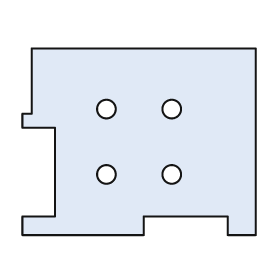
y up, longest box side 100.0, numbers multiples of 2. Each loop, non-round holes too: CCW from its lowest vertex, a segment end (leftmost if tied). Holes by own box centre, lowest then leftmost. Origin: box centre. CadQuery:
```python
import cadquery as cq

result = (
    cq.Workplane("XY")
    .moveTo(-50.0, -40.0)
    .lineTo(2.0, -40.0)
    .lineTo(2.0, -32.0)
    .lineTo(38.0, -32.0)
    .lineTo(38.0, -40.0)
    .lineTo(50.0, -40.0)
    .lineTo(50.0, 40.0)
    .lineTo(-46.0, 40.0)
    .lineTo(-46.0, 12.0)
    .lineTo(-50.0, 12.0)
    .lineTo(-50.0, 6.0)
    .lineTo(-36.0, 6.0)
    .lineTo(-36.0, -32.0)
    .lineTo(-50.0, -32.0)
    .close()
    .moveTo(-14.0, -14.0)
    .circle(4.0)
    .moveTo(14.0, -14.0)
    .circle(4.0)
    .moveTo(-14.0, 14.0)
    .circle(4.0)
    .moveTo(14.0, 14.0)
    .circle(4.0)
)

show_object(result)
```